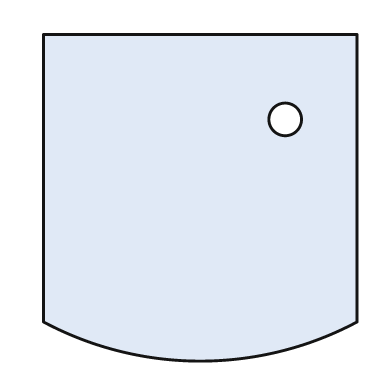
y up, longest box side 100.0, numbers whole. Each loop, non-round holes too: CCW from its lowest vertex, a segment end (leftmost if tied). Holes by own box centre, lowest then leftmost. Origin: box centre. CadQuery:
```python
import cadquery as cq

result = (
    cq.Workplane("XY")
    .moveTo(-48.0, -38.0)
    .threePointArc((0.0, -50.0), (48.0, -38.0))
    .lineTo(48.0, 50.0)
    .lineTo(-48.0, 50.0)
    .close()
    .moveTo(26.0, 24.0)
    .circle(5.0)
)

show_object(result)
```